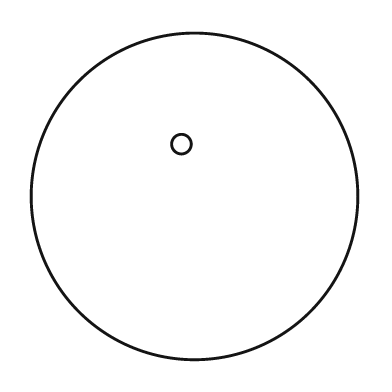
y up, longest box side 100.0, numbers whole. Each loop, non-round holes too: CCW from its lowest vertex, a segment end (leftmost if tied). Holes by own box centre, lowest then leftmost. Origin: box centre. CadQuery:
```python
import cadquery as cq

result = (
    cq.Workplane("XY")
    .moveTo(0.0, 0.0)
    .circle(50.0)
    .moveTo(-4.0, 16.0)
    .circle(3.0)
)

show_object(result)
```